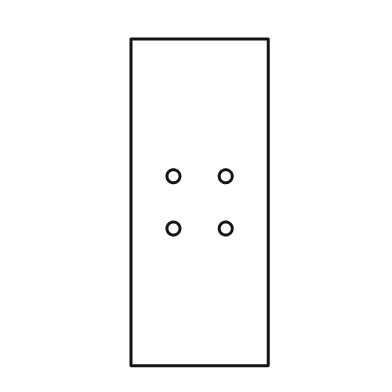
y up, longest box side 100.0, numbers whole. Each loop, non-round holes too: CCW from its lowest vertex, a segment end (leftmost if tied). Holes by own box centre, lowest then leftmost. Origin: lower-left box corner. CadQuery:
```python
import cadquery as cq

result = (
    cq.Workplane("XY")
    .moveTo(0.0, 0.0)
    .lineTo(42.0, 0.0)
    .lineTo(42.0, 100.0)
    .lineTo(0.0, 100.0)
    .close()
    .moveTo(13.0, 42.0)
    .circle(2.0)
    .moveTo(29.0, 42.0)
    .circle(2.0)
    .moveTo(13.0, 58.0)
    .circle(2.0)
    .moveTo(29.0, 58.0)
    .circle(2.0)
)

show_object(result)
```